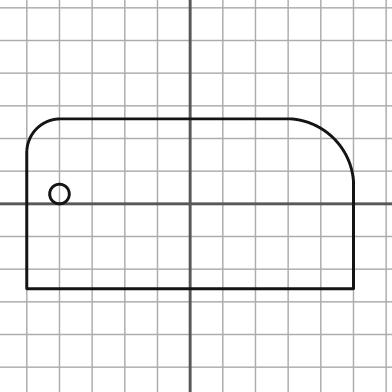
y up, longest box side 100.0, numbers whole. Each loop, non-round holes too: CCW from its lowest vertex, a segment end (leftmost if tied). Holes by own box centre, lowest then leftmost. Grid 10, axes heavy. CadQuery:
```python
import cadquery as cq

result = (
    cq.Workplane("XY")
    .moveTo(-50.0, -26.0)
    .lineTo(50.0, -26.0)
    .lineTo(50.0, 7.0)
    .threePointArc((44.0, 20.0), (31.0, 26.0))
    .lineTo(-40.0, 26.0)
    .threePointArc((-47.0, 23.0), (-50.0, 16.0))
    .close()
    .moveTo(-40.0, 3.0)
    .circle(3.0)
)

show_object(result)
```